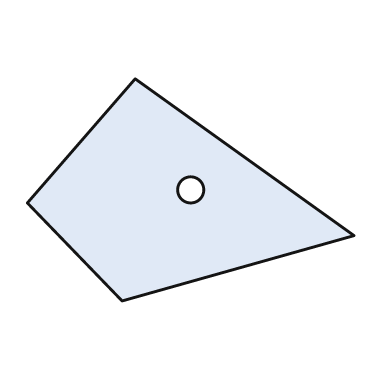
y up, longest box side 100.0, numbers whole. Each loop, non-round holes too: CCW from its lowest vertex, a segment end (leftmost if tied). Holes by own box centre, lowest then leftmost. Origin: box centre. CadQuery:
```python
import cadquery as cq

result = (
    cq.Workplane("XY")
    .moveTo(-21.0, -34.0)
    .lineTo(50.0, -14.0)
    .lineTo(-17.0, 34.0)
    .lineTo(-50.0, -4.0)
    .close()
    .moveTo(0.0, 0.0)
    .circle(4.0)
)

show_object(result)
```